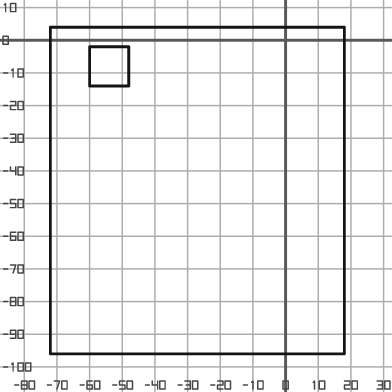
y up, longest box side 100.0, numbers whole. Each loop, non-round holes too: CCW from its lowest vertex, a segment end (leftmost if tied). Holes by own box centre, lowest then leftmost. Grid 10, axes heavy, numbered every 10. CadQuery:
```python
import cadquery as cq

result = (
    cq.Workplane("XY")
    .moveTo(-72.0, -96.0)
    .lineTo(18.0, -96.0)
    .lineTo(18.0, 4.0)
    .lineTo(-72.0, 4.0)
    .close()
    .moveTo(-60.0, -14.0)
    .lineTo(-48.0, -14.0)
    .lineTo(-48.0, -2.0)
    .lineTo(-60.0, -2.0)
    .close()
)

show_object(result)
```